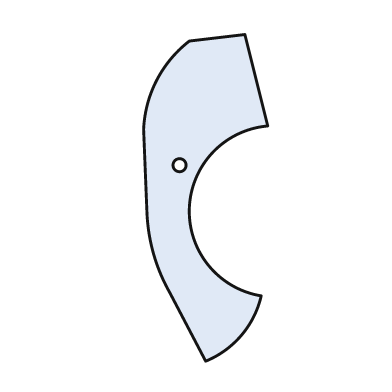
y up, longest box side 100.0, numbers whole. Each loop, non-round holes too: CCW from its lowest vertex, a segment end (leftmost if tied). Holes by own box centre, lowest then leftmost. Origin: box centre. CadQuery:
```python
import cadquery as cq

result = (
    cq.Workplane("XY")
    .moveTo(0.0, -50.0)
    .threePointArc((11.0, -42.0), (17.0, -30.0))
    .threePointArc((-5.0, -3.0), (19.0, 22.0))
    .lineTo(12.0, 50.0)
    .lineTo(-5.0, 48.0)
    .threePointArc((-15.0, 36.0), (-19.0, 21.0))
    .lineTo(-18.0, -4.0)
    .threePointArc((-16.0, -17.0), (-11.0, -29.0))
    .close()
    .moveTo(-8.0, 10.0)
    .circle(2.0)
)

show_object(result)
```